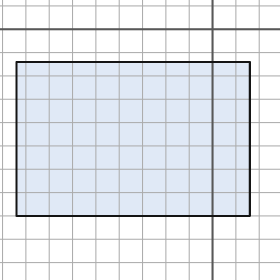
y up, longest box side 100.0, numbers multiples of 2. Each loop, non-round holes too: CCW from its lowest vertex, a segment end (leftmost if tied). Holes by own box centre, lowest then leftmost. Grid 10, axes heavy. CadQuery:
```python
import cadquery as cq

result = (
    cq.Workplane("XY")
    .moveTo(-84.0, -80.0)
    .lineTo(16.0, -80.0)
    .lineTo(16.0, -14.0)
    .lineTo(-84.0, -14.0)
    .close()
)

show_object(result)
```